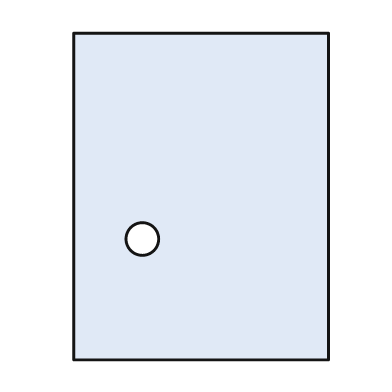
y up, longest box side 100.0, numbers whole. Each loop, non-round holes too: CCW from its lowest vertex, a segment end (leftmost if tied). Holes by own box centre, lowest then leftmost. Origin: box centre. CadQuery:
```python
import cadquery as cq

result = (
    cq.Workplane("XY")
    .moveTo(-39.0, -50.0)
    .lineTo(39.0, -50.0)
    .lineTo(39.0, 50.0)
    .lineTo(-39.0, 50.0)
    .close()
    .moveTo(-18.0, -13.0)
    .circle(5.0)
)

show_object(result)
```